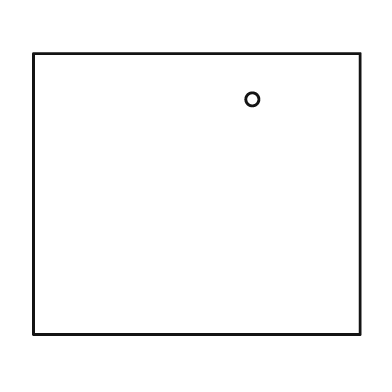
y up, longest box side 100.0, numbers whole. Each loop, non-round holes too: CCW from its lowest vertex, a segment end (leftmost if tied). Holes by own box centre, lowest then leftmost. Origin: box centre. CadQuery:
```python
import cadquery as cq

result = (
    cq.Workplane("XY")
    .moveTo(-50.0, -43.0)
    .lineTo(50.0, -43.0)
    .lineTo(50.0, 43.0)
    .lineTo(-50.0, 43.0)
    .close()
    .moveTo(17.0, 29.0)
    .circle(2.0)
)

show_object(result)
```